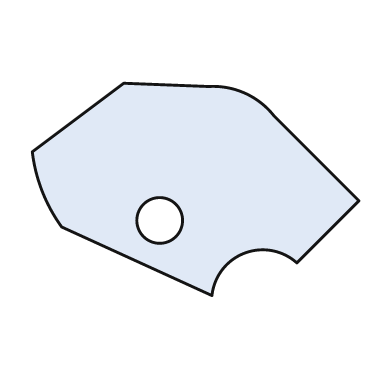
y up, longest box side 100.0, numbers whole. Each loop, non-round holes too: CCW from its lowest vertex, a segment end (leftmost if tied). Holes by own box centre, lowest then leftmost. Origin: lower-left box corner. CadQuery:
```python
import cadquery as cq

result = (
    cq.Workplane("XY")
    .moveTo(55.0, 0.0)
    .threePointArc((65.0, 13.0), (81.0, 10.0))
    .lineTo(100.0, 29.0)
    .lineTo(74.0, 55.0)
    .threePointArc((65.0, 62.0), (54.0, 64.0))
    .lineTo(28.0, 65.0)
    .lineTo(0.0, 44.0)
    .threePointArc((3.0, 32.0), (9.0, 21.0))
    .close()
    .moveTo(39.0, 23.0)
    .circle(7.0)
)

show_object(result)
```